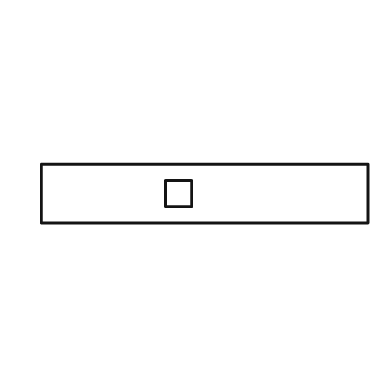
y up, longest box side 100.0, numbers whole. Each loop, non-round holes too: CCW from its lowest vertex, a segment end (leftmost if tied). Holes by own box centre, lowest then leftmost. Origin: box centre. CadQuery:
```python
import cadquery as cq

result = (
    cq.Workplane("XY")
    .moveTo(-50.0, -9.0)
    .lineTo(50.0, -9.0)
    .lineTo(50.0, 9.0)
    .lineTo(-50.0, 9.0)
    .close()
    .moveTo(-12.0, -4.0)
    .lineTo(-4.0, -4.0)
    .lineTo(-4.0, 4.0)
    .lineTo(-12.0, 4.0)
    .close()
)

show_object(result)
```